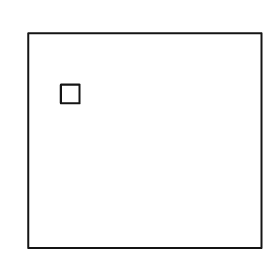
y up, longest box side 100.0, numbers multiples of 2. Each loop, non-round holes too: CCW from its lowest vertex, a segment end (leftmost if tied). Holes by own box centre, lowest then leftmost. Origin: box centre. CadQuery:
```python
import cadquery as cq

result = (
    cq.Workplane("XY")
    .moveTo(-50.0, -46.0)
    .lineTo(50.0, -46.0)
    .lineTo(50.0, 46.0)
    .lineTo(-50.0, 46.0)
    .close()
    .moveTo(-36.0, 16.0)
    .lineTo(-28.0, 16.0)
    .lineTo(-28.0, 24.0)
    .lineTo(-36.0, 24.0)
    .close()
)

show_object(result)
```